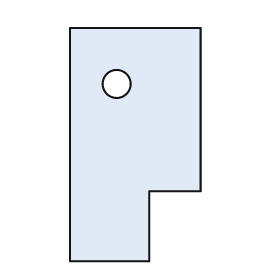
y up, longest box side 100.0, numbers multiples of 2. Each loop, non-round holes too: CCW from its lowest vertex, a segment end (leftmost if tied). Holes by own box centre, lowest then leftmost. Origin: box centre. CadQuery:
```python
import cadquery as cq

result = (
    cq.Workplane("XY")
    .moveTo(-28.0, -50.0)
    .lineTo(6.0, -50.0)
    .lineTo(6.0, -20.0)
    .lineTo(28.0, -20.0)
    .lineTo(28.0, 50.0)
    .lineTo(-28.0, 50.0)
    .close()
    .moveTo(-8.0, 26.0)
    .circle(6.0)
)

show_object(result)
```